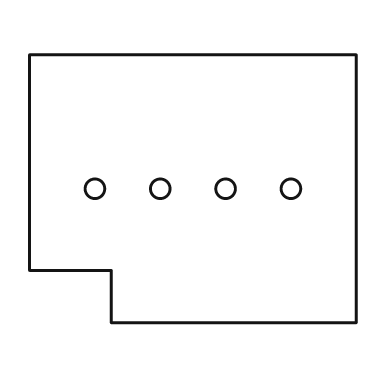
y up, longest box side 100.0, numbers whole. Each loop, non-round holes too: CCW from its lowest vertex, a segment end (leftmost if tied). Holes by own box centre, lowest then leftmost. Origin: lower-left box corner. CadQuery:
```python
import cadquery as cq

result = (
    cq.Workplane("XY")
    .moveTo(25.0, 0.0)
    .lineTo(100.0, 0.0)
    .lineTo(100.0, 82.0)
    .lineTo(0.0, 82.0)
    .lineTo(0.0, 16.0)
    .lineTo(25.0, 16.0)
    .close()
    .moveTo(20.0, 41.0)
    .circle(3.0)
    .moveTo(40.0, 41.0)
    .circle(3.0)
    .moveTo(60.0, 41.0)
    .circle(3.0)
    .moveTo(80.0, 41.0)
    .circle(3.0)
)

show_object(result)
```